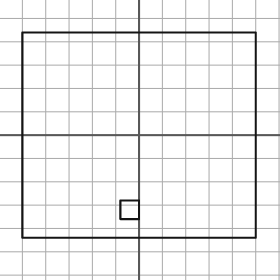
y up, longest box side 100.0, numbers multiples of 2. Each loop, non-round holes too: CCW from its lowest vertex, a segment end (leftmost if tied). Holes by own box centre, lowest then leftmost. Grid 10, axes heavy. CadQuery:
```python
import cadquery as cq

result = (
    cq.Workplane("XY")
    .moveTo(-50.0, -44.0)
    .lineTo(50.0, -44.0)
    .lineTo(50.0, 44.0)
    .lineTo(-50.0, 44.0)
    .close()
    .moveTo(-8.0, -36.0)
    .lineTo(0.0, -36.0)
    .lineTo(0.0, -28.0)
    .lineTo(-8.0, -28.0)
    .close()
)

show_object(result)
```